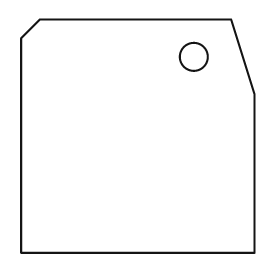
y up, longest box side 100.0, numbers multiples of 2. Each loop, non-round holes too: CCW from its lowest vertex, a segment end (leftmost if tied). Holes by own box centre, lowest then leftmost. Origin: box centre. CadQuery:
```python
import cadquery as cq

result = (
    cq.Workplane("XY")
    .moveTo(-50.0, -50.0)
    .lineTo(50.0, -50.0)
    .lineTo(50.0, 18.0)
    .lineTo(40.0, 50.0)
    .lineTo(-42.0, 50.0)
    .lineTo(-50.0, 42.0)
    .close()
    .moveTo(24.0, 34.0)
    .circle(6.0)
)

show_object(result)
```